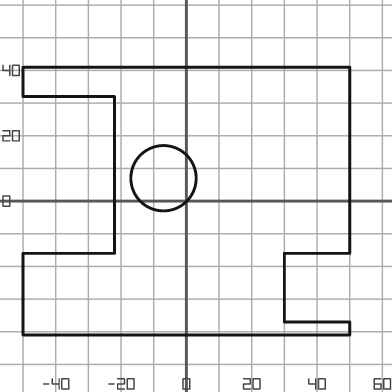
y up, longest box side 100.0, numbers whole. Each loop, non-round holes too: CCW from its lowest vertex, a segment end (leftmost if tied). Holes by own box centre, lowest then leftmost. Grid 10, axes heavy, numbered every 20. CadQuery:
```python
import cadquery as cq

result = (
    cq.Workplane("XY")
    .moveTo(-50.0, -41.0)
    .lineTo(50.0, -41.0)
    .lineTo(50.0, -37.0)
    .lineTo(30.0, -37.0)
    .lineTo(30.0, -16.0)
    .lineTo(50.0, -16.0)
    .lineTo(50.0, 41.0)
    .lineTo(-50.0, 41.0)
    .lineTo(-50.0, 32.0)
    .lineTo(-22.0, 32.0)
    .lineTo(-22.0, -16.0)
    .lineTo(-50.0, -16.0)
    .close()
    .moveTo(-7.0, 7.0)
    .circle(10.0)
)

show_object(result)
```